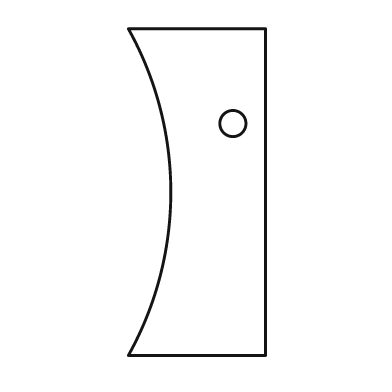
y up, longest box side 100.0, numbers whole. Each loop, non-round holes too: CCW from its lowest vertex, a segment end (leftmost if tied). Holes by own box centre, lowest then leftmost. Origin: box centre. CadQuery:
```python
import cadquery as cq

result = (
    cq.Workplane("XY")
    .moveTo(-21.0, -50.0)
    .lineTo(21.0, -50.0)
    .lineTo(21.0, 50.0)
    .lineTo(-21.0, 50.0)
    .threePointArc((-8.0, 0.0), (-21.0, -50.0))
    .close()
    .moveTo(11.0, 21.0)
    .circle(4.0)
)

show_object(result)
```